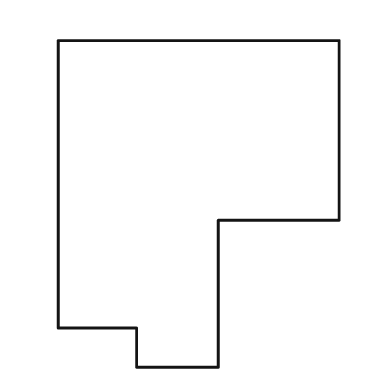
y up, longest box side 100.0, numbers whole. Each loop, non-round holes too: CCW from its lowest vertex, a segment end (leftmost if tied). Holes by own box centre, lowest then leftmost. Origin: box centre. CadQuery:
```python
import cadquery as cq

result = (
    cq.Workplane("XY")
    .moveTo(-19.0, -50.0)
    .lineTo(6.0, -50.0)
    .lineTo(6.0, -5.0)
    .lineTo(43.0, -5.0)
    .lineTo(43.0, 50.0)
    .lineTo(-43.0, 50.0)
    .lineTo(-43.0, -38.0)
    .lineTo(-19.0, -38.0)
    .close()
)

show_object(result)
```